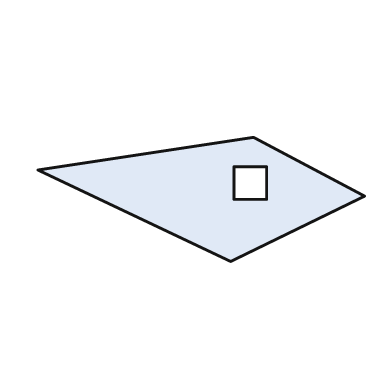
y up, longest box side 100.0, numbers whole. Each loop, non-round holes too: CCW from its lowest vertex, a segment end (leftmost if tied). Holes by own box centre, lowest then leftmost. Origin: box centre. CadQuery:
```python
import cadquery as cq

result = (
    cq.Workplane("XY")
    .moveTo(9.0, -19.0)
    .lineTo(50.0, 1.0)
    .lineTo(16.0, 19.0)
    .lineTo(-50.0, 9.0)
    .close()
    .moveTo(10.0, 0.0)
    .lineTo(20.0, 0.0)
    .lineTo(20.0, 10.0)
    .lineTo(10.0, 10.0)
    .close()
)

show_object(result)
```